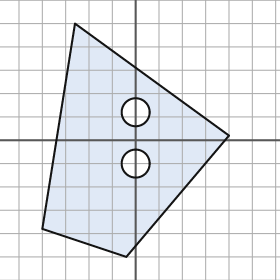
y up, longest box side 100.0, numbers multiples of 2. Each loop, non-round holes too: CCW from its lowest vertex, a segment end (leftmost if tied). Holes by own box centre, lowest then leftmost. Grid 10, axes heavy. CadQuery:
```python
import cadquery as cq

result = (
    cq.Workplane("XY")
    .moveTo(-4.0, -50.0)
    .lineTo(40.0, 2.0)
    .lineTo(-26.0, 50.0)
    .lineTo(-40.0, -38.0)
    .close()
    .moveTo(0.0, -10.0)
    .circle(6.0)
    .moveTo(0.0, 12.0)
    .circle(6.0)
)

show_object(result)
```